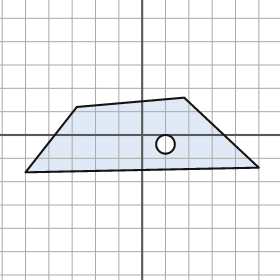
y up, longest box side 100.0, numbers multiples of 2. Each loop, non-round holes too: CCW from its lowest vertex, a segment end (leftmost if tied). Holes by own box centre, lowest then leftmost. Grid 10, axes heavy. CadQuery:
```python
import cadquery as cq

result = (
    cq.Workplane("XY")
    .moveTo(-50.0, -16.0)
    .lineTo(50.0, -14.0)
    .lineTo(18.0, 16.0)
    .lineTo(-28.0, 12.0)
    .close()
    .moveTo(10.0, -4.0)
    .circle(4.0)
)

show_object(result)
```